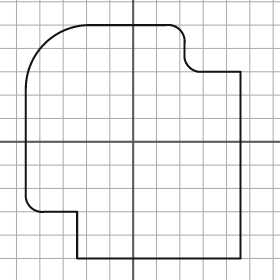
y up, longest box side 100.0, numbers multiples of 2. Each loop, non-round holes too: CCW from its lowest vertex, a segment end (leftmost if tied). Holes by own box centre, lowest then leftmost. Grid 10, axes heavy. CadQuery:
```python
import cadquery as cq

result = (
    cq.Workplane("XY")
    .moveTo(-24.0, -50.0)
    .lineTo(46.0, -50.0)
    .lineTo(46.0, 30.0)
    .lineTo(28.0, 30.0)
    .threePointArc((24.0, 32.0), (22.0, 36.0))
    .lineTo(22.0, 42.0)
    .threePointArc((20.0, 48.0), (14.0, 50.0))
    .lineTo(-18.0, 50.0)
    .threePointArc((-38.0, 42.0), (-46.0, 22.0))
    .lineTo(-46.0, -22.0)
    .threePointArc((-44.0, -28.0), (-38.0, -30.0))
    .lineTo(-24.0, -30.0)
    .close()
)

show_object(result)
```